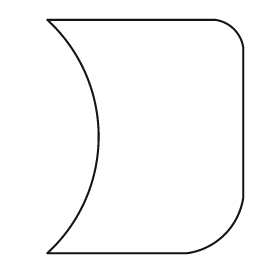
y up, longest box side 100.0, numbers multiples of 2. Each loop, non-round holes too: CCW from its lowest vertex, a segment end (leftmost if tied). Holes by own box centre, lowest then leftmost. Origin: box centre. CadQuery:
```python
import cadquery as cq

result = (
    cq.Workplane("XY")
    .moveTo(-42.0, -50.0)
    .lineTo(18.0, -50.0)
    .threePointArc((34.0, -42.0), (42.0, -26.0))
    .lineTo(42.0, 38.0)
    .threePointArc((38.0, 46.0), (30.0, 50.0))
    .lineTo(-42.0, 50.0)
    .threePointArc((-20.0, 0.0), (-42.0, -50.0))
    .close()
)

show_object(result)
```